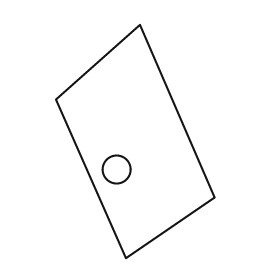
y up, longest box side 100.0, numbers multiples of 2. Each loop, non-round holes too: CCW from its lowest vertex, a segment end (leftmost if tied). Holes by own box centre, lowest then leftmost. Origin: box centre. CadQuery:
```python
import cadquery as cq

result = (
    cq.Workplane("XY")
    .moveTo(-4.0, -50.0)
    .lineTo(34.0, -24.0)
    .lineTo(2.0, 50.0)
    .lineTo(-34.0, 18.0)
    .close()
    .moveTo(-8.0, -12.0)
    .circle(6.0)
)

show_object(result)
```